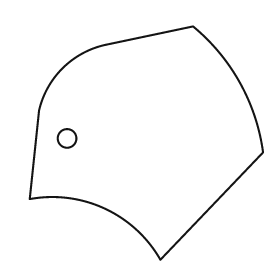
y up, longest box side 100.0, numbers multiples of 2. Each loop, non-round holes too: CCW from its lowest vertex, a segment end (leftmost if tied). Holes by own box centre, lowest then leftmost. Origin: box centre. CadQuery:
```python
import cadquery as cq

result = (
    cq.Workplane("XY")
    .moveTo(6.0, -50.0)
    .lineTo(50.0, -4.0)
    .threePointArc((40.0, 26.0), (20.0, 50.0))
    .lineTo(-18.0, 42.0)
    .threePointArc((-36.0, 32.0), (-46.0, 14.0))
    .lineTo(-50.0, -24.0)
    .threePointArc((-18.0, -28.0), (6.0, -50.0))
    .close()
    .moveTo(-34.0, 2.0)
    .circle(4.0)
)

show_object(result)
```